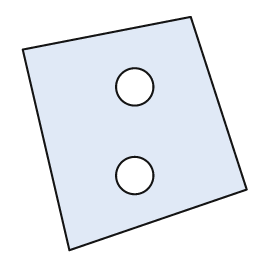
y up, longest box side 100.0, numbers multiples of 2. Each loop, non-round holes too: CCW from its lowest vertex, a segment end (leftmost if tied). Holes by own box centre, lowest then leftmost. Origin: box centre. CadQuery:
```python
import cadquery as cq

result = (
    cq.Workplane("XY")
    .moveTo(-28.0, -50.0)
    .lineTo(48.0, -24.0)
    .lineTo(24.0, 50.0)
    .lineTo(-48.0, 36.0)
    .close()
    .moveTo(0.0, -18.0)
    .circle(8.0)
    .moveTo(0.0, 20.0)
    .circle(8.0)
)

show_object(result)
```